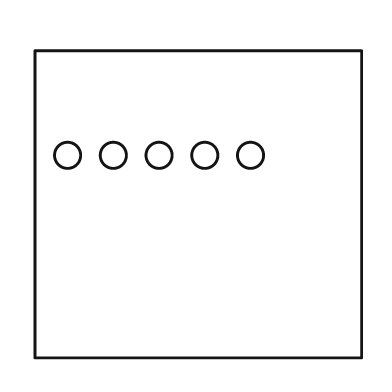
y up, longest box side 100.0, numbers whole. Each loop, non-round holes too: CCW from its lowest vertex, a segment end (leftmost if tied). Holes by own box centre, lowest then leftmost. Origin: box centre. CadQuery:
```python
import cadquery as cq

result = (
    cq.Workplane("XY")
    .moveTo(-50.0, -47.0)
    .lineTo(50.0, -47.0)
    .lineTo(50.0, 47.0)
    .lineTo(-50.0, 47.0)
    .close()
    .moveTo(-40.0, 15.0)
    .circle(4.0)
    .moveTo(-26.0, 15.0)
    .circle(4.0)
    .moveTo(-12.0, 15.0)
    .circle(4.0)
    .moveTo(2.0, 15.0)
    .circle(4.0)
    .moveTo(16.0, 15.0)
    .circle(4.0)
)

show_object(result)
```